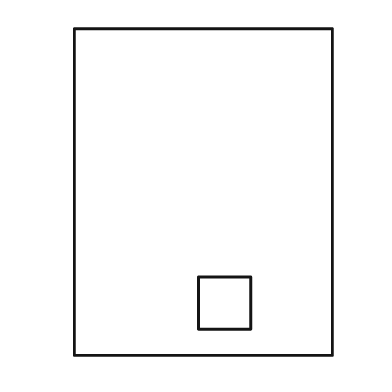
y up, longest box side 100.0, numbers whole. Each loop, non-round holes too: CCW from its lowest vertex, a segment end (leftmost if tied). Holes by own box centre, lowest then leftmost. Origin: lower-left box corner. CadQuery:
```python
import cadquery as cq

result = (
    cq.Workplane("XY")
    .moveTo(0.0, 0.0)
    .lineTo(79.0, 0.0)
    .lineTo(79.0, 100.0)
    .lineTo(0.0, 100.0)
    .close()
    .moveTo(38.0, 8.0)
    .lineTo(54.0, 8.0)
    .lineTo(54.0, 24.0)
    .lineTo(38.0, 24.0)
    .close()
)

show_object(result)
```